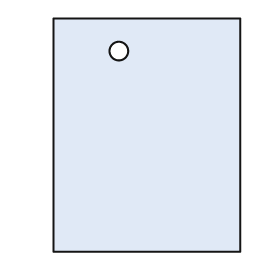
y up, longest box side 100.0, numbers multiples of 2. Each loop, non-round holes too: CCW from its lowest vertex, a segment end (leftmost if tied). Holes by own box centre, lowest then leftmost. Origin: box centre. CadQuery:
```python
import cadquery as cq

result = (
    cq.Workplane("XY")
    .moveTo(-40.0, -50.0)
    .lineTo(40.0, -50.0)
    .lineTo(40.0, 50.0)
    .lineTo(-40.0, 50.0)
    .close()
    .moveTo(-12.0, 36.0)
    .circle(4.0)
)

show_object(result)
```